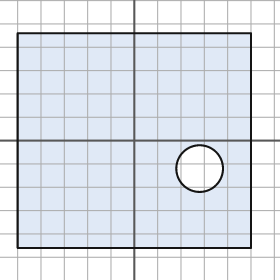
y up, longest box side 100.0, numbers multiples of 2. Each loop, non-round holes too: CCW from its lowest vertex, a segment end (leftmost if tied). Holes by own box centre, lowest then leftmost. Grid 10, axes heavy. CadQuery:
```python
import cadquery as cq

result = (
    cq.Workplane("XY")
    .moveTo(-50.0, -46.0)
    .lineTo(50.0, -46.0)
    .lineTo(50.0, 46.0)
    .lineTo(-50.0, 46.0)
    .close()
    .moveTo(28.0, -12.0)
    .circle(10.0)
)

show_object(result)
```